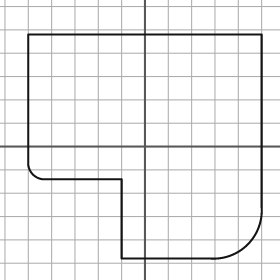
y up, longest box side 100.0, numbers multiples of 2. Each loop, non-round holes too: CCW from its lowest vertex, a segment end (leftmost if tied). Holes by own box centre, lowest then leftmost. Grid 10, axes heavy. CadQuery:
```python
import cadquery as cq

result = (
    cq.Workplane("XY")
    .moveTo(-10.0, -48.0)
    .lineTo(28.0, -48.0)
    .threePointArc((44.0, -42.0), (50.0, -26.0))
    .lineTo(50.0, 48.0)
    .lineTo(-50.0, 48.0)
    .lineTo(-50.0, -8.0)
    .threePointArc((-48.0, -12.0), (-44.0, -14.0))
    .lineTo(-10.0, -14.0)
    .close()
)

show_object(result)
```